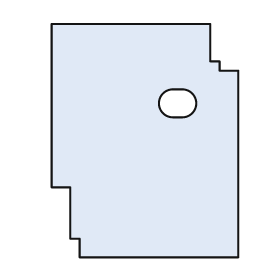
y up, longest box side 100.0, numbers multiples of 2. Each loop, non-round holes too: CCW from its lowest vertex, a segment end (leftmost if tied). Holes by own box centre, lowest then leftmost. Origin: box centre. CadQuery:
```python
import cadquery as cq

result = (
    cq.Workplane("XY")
    .moveTo(-28.0, -50.0)
    .lineTo(40.0, -50.0)
    .lineTo(40.0, 30.0)
    .lineTo(32.0, 30.0)
    .lineTo(32.0, 34.0)
    .lineTo(28.0, 34.0)
    .lineTo(28.0, 50.0)
    .lineTo(-40.0, 50.0)
    .lineTo(-40.0, -20.0)
    .lineTo(-32.0, -20.0)
    .lineTo(-32.0, -42.0)
    .lineTo(-28.0, -42.0)
    .close()
    .moveTo(12.0, 10.0)
    .lineTo(16.0, 10.0)
    .threePointArc((22.0, 16.0), (16.0, 22.0))
    .lineTo(12.0, 22.0)
    .threePointArc((6.0, 16.0), (12.0, 10.0))
    .close()
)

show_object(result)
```